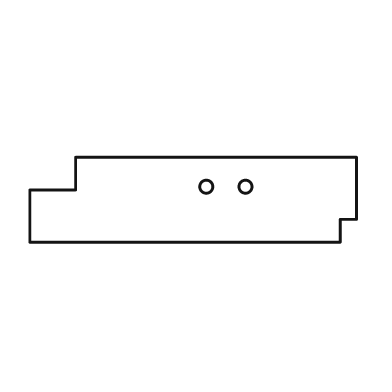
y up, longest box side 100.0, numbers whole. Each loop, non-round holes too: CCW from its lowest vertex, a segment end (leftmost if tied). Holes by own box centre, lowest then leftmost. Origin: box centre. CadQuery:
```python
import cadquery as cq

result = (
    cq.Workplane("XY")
    .moveTo(-50.0, -13.0)
    .lineTo(45.0, -13.0)
    .lineTo(45.0, -6.0)
    .lineTo(50.0, -6.0)
    .lineTo(50.0, 13.0)
    .lineTo(-36.0, 13.0)
    .lineTo(-36.0, 3.0)
    .lineTo(-50.0, 3.0)
    .close()
    .moveTo(4.0, 4.0)
    .circle(2.0)
    .moveTo(16.0, 4.0)
    .circle(2.0)
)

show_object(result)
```